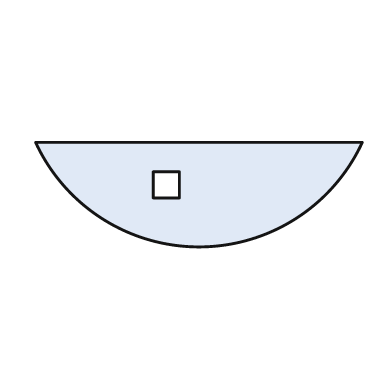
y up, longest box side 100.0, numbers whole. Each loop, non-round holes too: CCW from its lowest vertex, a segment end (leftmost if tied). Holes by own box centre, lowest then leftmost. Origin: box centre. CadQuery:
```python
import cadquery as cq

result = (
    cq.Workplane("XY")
    .moveTo(-50.0, 16.0)
    .threePointArc((0.0, -16.0), (50.0, 16.0))
    .close()
    .moveTo(-14.0, -1.0)
    .lineTo(-6.0, -1.0)
    .lineTo(-6.0, 7.0)
    .lineTo(-14.0, 7.0)
    .close()
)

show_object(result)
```